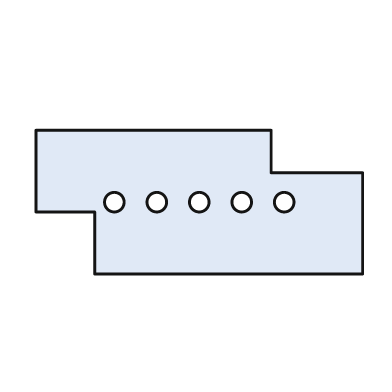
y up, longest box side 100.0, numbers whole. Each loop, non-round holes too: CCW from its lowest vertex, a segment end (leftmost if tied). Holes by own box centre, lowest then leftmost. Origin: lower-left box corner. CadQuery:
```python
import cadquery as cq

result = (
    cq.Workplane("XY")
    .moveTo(18.0, 0.0)
    .lineTo(100.0, 0.0)
    .lineTo(100.0, 31.0)
    .lineTo(72.0, 31.0)
    .lineTo(72.0, 44.0)
    .lineTo(0.0, 44.0)
    .lineTo(0.0, 19.0)
    .lineTo(18.0, 19.0)
    .close()
    .moveTo(24.0, 22.0)
    .circle(3.0)
    .moveTo(37.0, 22.0)
    .circle(3.0)
    .moveTo(50.0, 22.0)
    .circle(3.0)
    .moveTo(63.0, 22.0)
    .circle(3.0)
    .moveTo(76.0, 22.0)
    .circle(3.0)
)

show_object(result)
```